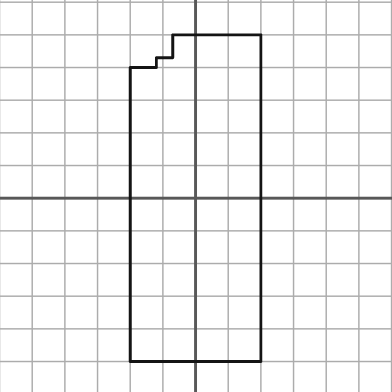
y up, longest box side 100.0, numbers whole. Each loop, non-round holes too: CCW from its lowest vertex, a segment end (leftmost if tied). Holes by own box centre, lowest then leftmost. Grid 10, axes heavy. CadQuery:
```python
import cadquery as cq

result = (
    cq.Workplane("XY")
    .moveTo(-20.0, -50.0)
    .lineTo(20.0, -50.0)
    .lineTo(20.0, 50.0)
    .lineTo(-7.0, 50.0)
    .lineTo(-7.0, 43.0)
    .lineTo(-12.0, 43.0)
    .lineTo(-12.0, 40.0)
    .lineTo(-20.0, 40.0)
    .close()
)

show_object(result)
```